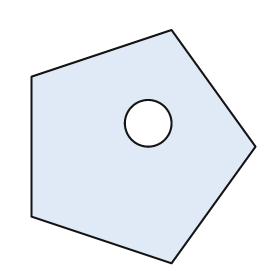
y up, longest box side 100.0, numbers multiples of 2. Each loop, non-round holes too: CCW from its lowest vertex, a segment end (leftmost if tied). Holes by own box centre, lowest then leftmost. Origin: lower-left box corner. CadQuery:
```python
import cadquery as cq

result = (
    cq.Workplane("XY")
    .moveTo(60.0, 0.0)
    .lineTo(96.0, 50.0)
    .lineTo(60.0, 100.0)
    .lineTo(0.0, 80.0)
    .lineTo(0.0, 20.0)
    .close()
    .moveTo(50.0, 60.0)
    .circle(10.0)
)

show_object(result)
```